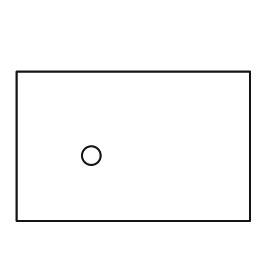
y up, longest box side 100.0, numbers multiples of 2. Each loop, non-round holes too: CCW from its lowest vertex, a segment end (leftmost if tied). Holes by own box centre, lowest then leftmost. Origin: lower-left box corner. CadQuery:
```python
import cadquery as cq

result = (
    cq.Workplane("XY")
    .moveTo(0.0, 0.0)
    .lineTo(100.0, 0.0)
    .lineTo(100.0, 64.0)
    .lineTo(0.0, 64.0)
    .close()
    .moveTo(32.0, 28.0)
    .circle(4.0)
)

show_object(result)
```